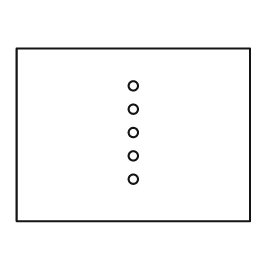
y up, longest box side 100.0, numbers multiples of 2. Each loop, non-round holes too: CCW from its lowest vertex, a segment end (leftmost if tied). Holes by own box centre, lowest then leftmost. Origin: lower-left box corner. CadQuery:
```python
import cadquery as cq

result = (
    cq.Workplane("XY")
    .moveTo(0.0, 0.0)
    .lineTo(100.0, 0.0)
    .lineTo(100.0, 74.0)
    .lineTo(0.0, 74.0)
    .close()
    .moveTo(50.0, 18.0)
    .circle(2.0)
    .moveTo(50.0, 28.0)
    .circle(2.0)
    .moveTo(50.0, 38.0)
    .circle(2.0)
    .moveTo(50.0, 48.0)
    .circle(2.0)
    .moveTo(50.0, 58.0)
    .circle(2.0)
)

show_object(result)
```